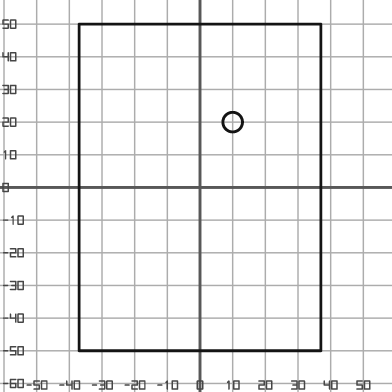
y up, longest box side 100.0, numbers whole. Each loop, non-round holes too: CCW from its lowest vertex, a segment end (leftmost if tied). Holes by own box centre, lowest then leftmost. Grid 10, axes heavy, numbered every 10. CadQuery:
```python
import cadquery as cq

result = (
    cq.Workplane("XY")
    .moveTo(-37.0, -50.0)
    .lineTo(37.0, -50.0)
    .lineTo(37.0, 50.0)
    .lineTo(-37.0, 50.0)
    .close()
    .moveTo(10.0, 20.0)
    .circle(3.0)
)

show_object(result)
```